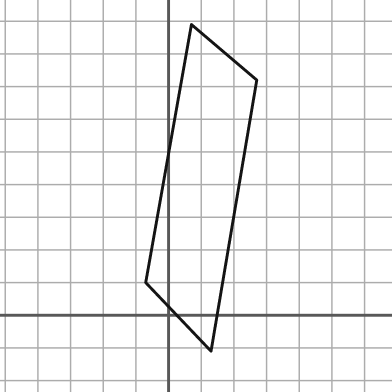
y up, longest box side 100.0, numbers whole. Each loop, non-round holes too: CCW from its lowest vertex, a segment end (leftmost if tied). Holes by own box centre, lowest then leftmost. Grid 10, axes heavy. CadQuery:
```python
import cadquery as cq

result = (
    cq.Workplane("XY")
    .moveTo(13.0, -11.0)
    .lineTo(27.0, 72.0)
    .lineTo(7.0, 89.0)
    .lineTo(-7.0, 10.0)
    .close()
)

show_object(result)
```